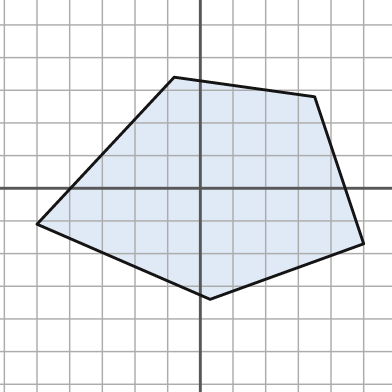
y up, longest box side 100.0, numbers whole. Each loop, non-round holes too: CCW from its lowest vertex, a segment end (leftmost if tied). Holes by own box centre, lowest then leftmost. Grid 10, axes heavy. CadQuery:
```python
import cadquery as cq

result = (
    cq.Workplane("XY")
    .moveTo(3.0, -34.0)
    .lineTo(50.0, -17.0)
    .lineTo(35.0, 28.0)
    .lineTo(-8.0, 34.0)
    .lineTo(-50.0, -11.0)
    .close()
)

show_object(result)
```